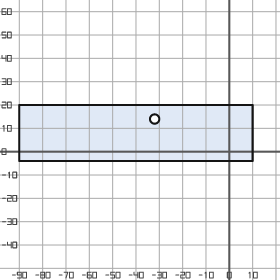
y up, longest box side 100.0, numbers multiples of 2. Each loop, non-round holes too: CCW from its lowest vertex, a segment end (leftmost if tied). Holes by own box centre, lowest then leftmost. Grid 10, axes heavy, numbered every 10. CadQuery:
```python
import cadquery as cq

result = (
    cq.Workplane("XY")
    .moveTo(-90.0, -4.0)
    .lineTo(10.0, -4.0)
    .lineTo(10.0, 20.0)
    .lineTo(-90.0, 20.0)
    .close()
    .moveTo(-32.0, 14.0)
    .circle(2.0)
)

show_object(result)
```